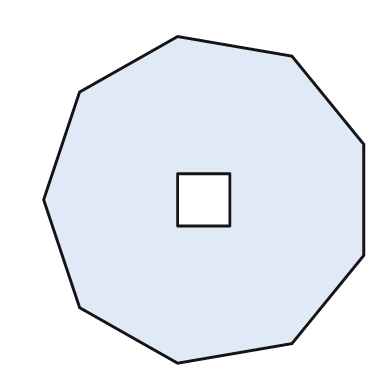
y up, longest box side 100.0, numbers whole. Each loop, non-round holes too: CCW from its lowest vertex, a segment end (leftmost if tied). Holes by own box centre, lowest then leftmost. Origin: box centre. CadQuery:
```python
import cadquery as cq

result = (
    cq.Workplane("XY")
    .moveTo(-8.0, -50.0)
    .lineTo(27.0, -44.0)
    .lineTo(49.0, -17.0)
    .lineTo(49.0, 17.0)
    .lineTo(27.0, 44.0)
    .lineTo(-8.0, 50.0)
    .lineTo(-38.0, 33.0)
    .lineTo(-49.0, 0.0)
    .lineTo(-38.0, -33.0)
    .close()
    .moveTo(-8.0, -8.0)
    .lineTo(8.0, -8.0)
    .lineTo(8.0, 8.0)
    .lineTo(-8.0, 8.0)
    .close()
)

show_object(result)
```